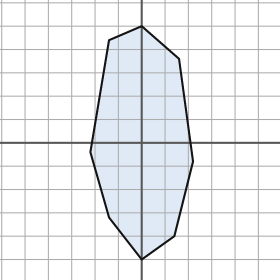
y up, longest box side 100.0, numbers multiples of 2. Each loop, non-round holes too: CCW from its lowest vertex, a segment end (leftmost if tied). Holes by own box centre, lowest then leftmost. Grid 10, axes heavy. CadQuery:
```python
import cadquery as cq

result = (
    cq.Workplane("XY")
    .moveTo(0.0, -50.0)
    .lineTo(14.0, -40.0)
    .lineTo(22.0, -8.0)
    .lineTo(16.0, 36.0)
    .lineTo(0.0, 50.0)
    .lineTo(-14.0, 44.0)
    .lineTo(-22.0, -4.0)
    .lineTo(-14.0, -32.0)
    .close()
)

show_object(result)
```